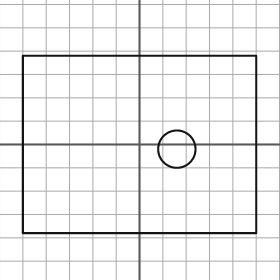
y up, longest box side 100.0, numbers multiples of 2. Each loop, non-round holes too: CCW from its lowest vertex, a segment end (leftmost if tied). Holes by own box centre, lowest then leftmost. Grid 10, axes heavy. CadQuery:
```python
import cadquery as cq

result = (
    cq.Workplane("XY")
    .moveTo(-50.0, -38.0)
    .lineTo(50.0, -38.0)
    .lineTo(50.0, 38.0)
    .lineTo(-50.0, 38.0)
    .close()
    .moveTo(16.0, -2.0)
    .circle(8.0)
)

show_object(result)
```